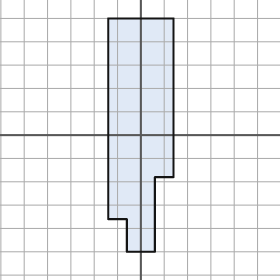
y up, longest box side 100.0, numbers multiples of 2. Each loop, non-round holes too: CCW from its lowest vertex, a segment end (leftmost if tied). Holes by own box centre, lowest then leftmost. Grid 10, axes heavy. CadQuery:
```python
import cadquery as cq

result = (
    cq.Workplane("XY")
    .moveTo(-6.0, -50.0)
    .lineTo(6.0, -50.0)
    .lineTo(6.0, -18.0)
    .lineTo(14.0, -18.0)
    .lineTo(14.0, 50.0)
    .lineTo(-14.0, 50.0)
    .lineTo(-14.0, -36.0)
    .lineTo(-6.0, -36.0)
    .close()
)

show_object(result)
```